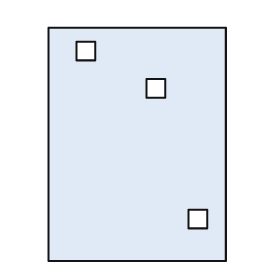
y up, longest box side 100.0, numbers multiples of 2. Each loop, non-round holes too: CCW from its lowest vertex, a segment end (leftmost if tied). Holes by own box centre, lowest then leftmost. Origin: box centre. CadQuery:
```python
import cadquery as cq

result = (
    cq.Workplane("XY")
    .moveTo(-38.0, -50.0)
    .lineTo(38.0, -50.0)
    .lineTo(38.0, 50.0)
    .lineTo(-38.0, 50.0)
    .close()
    .moveTo(22.0, -36.0)
    .lineTo(30.0, -36.0)
    .lineTo(30.0, -28.0)
    .lineTo(22.0, -28.0)
    .close()
    .moveTo(4.0, 20.0)
    .lineTo(12.0, 20.0)
    .lineTo(12.0, 28.0)
    .lineTo(4.0, 28.0)
    .close()
    .moveTo(-26.0, 36.0)
    .lineTo(-18.0, 36.0)
    .lineTo(-18.0, 44.0)
    .lineTo(-26.0, 44.0)
    .close()
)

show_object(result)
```